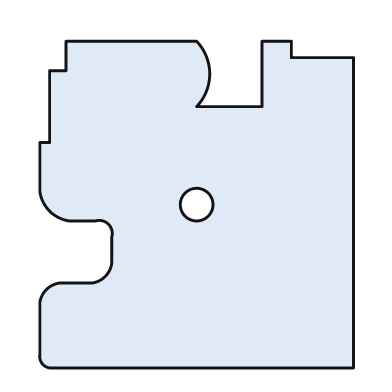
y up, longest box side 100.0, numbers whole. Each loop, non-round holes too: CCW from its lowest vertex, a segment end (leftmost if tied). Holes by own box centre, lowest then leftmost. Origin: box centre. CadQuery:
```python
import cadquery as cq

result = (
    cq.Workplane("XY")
    .moveTo(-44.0, -50.0)
    .lineTo(48.0, -50.0)
    .lineTo(48.0, 45.0)
    .lineTo(29.0, 45.0)
    .lineTo(29.0, 50.0)
    .lineTo(20.0, 50.0)
    .lineTo(20.0, 30.0)
    .lineTo(0.0, 30.0)
    .threePointArc((4.0, 40.0), (0.0, 50.0))
    .lineTo(-40.0, 50.0)
    .lineTo(-40.0, 41.0)
    .lineTo(-45.0, 41.0)
    .lineTo(-45.0, 19.0)
    .lineTo(-48.0, 19.0)
    .lineTo(-48.0, 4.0)
    .threePointArc((-45.0, -2.0), (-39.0, -5.0))
    .lineTo(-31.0, -5.0)
    .threePointArc((-27.0, -6.0), (-26.0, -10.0))
    .lineTo(-26.0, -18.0)
    .threePointArc((-28.0, -22.0), (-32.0, -24.0))
    .lineTo(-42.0, -24.0)
    .threePointArc((-46.0, -26.0), (-48.0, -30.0))
    .lineTo(-48.0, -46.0)
    .threePointArc((-47.0, -49.0), (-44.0, -50.0))
    .close()
    .moveTo(0.0, 0.0)
    .circle(5.0)
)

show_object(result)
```